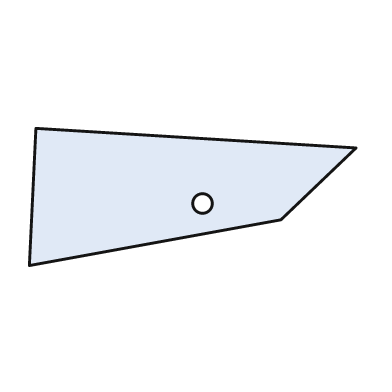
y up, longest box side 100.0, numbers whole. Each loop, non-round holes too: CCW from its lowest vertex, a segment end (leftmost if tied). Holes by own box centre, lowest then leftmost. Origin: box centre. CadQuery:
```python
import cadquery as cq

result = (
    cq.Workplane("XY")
    .moveTo(-50.0, -21.0)
    .lineTo(27.0, -7.0)
    .lineTo(50.0, 15.0)
    .lineTo(-48.0, 21.0)
    .close()
    .moveTo(3.0, -2.0)
    .circle(3.0)
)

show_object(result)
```